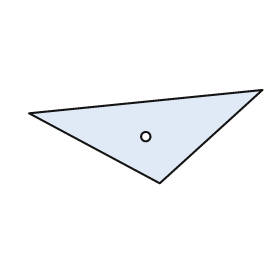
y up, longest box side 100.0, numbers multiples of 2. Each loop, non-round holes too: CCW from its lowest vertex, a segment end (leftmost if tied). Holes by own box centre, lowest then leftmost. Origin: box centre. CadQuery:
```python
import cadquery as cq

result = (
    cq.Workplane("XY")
    .moveTo(6.0, -20.0)
    .lineTo(50.0, 20.0)
    .lineTo(-50.0, 10.0)
    .close()
    .moveTo(0.0, 0.0)
    .circle(2.0)
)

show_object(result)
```